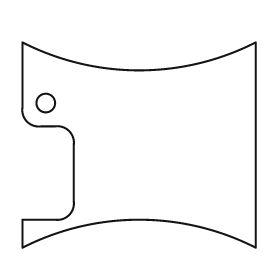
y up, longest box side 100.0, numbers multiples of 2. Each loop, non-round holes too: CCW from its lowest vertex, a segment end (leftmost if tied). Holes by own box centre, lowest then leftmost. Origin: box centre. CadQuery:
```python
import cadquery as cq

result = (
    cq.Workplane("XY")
    .moveTo(-50.0, -44.0)
    .threePointArc((0.0, -32.0), (50.0, -44.0))
    .lineTo(50.0, 44.0)
    .threePointArc((0.0, 32.0), (-50.0, 44.0))
    .lineTo(-50.0, 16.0)
    .threePointArc((-48.0, 10.0), (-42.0, 8.0))
    .lineTo(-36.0, 8.0)
    .threePointArc((-30.0, 6.0), (-28.0, 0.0))
    .lineTo(-28.0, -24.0)
    .threePointArc((-30.0, -30.0), (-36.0, -32.0))
    .lineTo(-50.0, -32.0)
    .close()
    .moveTo(-40.0, 18.0)
    .circle(4.0)
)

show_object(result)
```